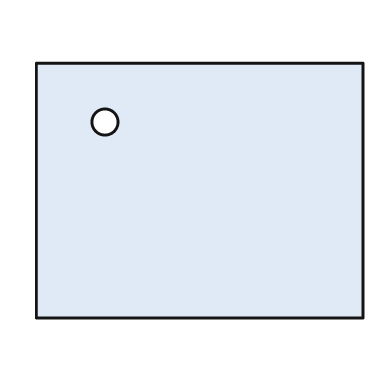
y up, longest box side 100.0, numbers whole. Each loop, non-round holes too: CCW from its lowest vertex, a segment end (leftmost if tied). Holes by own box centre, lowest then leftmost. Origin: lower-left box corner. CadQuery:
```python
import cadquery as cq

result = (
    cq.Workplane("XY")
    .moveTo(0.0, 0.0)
    .lineTo(100.0, 0.0)
    .lineTo(100.0, 78.0)
    .lineTo(0.0, 78.0)
    .close()
    .moveTo(21.0, 60.0)
    .circle(4.0)
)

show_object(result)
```